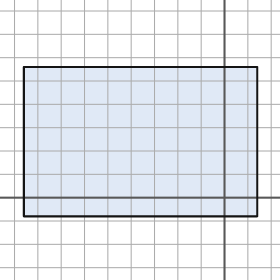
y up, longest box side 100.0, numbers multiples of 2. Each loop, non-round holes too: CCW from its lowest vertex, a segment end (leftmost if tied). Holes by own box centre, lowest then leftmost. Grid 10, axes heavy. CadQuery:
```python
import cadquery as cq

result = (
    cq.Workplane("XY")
    .moveTo(-86.0, -8.0)
    .lineTo(14.0, -8.0)
    .lineTo(14.0, 56.0)
    .lineTo(-86.0, 56.0)
    .close()
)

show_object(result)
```